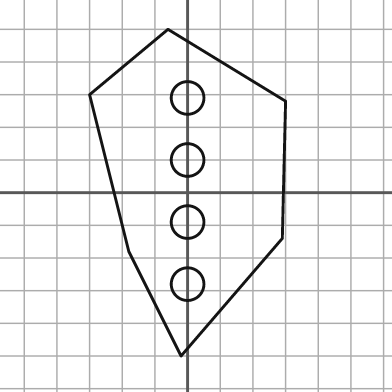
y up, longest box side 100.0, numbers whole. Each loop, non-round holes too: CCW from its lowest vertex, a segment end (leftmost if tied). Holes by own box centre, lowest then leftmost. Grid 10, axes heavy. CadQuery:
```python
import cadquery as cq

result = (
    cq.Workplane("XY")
    .moveTo(-2.0, -50.0)
    .lineTo(29.0, -14.0)
    .lineTo(30.0, 28.0)
    .lineTo(-6.0, 50.0)
    .lineTo(-30.0, 30.0)
    .lineTo(-18.0, -18.0)
    .close()
    .moveTo(0.0, -28.0)
    .circle(5.0)
    .moveTo(0.0, -9.0)
    .circle(5.0)
    .moveTo(0.0, 10.0)
    .circle(5.0)
    .moveTo(0.0, 29.0)
    .circle(5.0)
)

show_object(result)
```